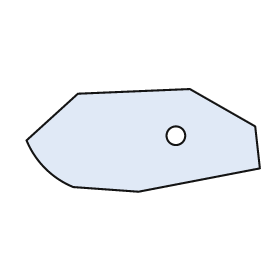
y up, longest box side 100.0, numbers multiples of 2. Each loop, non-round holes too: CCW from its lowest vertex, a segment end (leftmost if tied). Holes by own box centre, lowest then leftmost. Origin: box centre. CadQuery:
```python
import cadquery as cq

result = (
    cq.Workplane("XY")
    .moveTo(-2.0, -22.0)
    .lineTo(50.0, -12.0)
    .lineTo(48.0, 6.0)
    .lineTo(20.0, 22.0)
    .lineTo(-28.0, 20.0)
    .lineTo(-50.0, 0.0)
    .threePointArc((-42.0, -12.0), (-30.0, -20.0))
    .close()
    .moveTo(14.0, 2.0)
    .circle(4.0)
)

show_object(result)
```